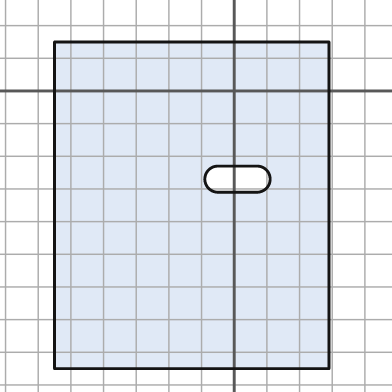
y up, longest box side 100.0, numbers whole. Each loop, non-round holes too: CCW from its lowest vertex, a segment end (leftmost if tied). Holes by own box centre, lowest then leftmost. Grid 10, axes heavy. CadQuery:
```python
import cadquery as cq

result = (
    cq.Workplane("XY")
    .moveTo(-55.0, -85.0)
    .lineTo(29.0, -85.0)
    .lineTo(29.0, 15.0)
    .lineTo(-55.0, 15.0)
    .close()
    .moveTo(-5.0, -31.0)
    .lineTo(7.0, -31.0)
    .threePointArc((11.0, -27.0), (7.0, -23.0))
    .lineTo(-5.0, -23.0)
    .threePointArc((-9.0, -27.0), (-5.0, -31.0))
    .close()
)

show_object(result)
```